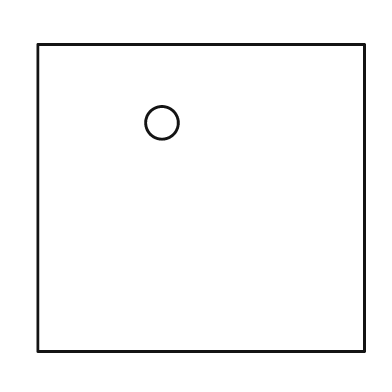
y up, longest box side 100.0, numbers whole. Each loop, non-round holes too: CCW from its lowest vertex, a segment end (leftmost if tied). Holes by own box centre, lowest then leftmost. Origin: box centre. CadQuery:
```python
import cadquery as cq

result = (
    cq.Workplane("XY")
    .moveTo(-50.0, -47.0)
    .lineTo(50.0, -47.0)
    .lineTo(50.0, 47.0)
    .lineTo(-50.0, 47.0)
    .close()
    .moveTo(-12.0, 23.0)
    .circle(5.0)
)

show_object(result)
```